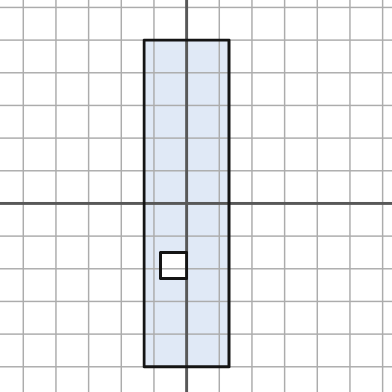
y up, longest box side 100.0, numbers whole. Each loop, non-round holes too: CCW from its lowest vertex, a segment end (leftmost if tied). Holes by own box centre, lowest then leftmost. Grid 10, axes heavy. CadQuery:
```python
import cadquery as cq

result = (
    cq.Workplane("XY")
    .moveTo(-13.0, -50.0)
    .lineTo(13.0, -50.0)
    .lineTo(13.0, 50.0)
    .lineTo(-13.0, 50.0)
    .close()
    .moveTo(-8.0, -23.0)
    .lineTo(0.0, -23.0)
    .lineTo(0.0, -15.0)
    .lineTo(-8.0, -15.0)
    .close()
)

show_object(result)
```